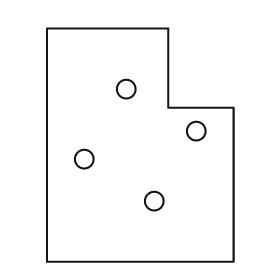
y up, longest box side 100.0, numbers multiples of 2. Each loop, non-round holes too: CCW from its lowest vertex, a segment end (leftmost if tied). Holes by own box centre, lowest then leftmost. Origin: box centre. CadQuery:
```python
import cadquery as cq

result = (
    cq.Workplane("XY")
    .moveTo(-40.0, -50.0)
    .lineTo(40.0, -50.0)
    .lineTo(40.0, 16.0)
    .lineTo(12.0, 16.0)
    .lineTo(12.0, 50.0)
    .lineTo(-40.0, 50.0)
    .close()
    .moveTo(6.0, -24.0)
    .circle(4.0)
    .moveTo(-24.0, -6.0)
    .circle(4.0)
    .moveTo(24.0, 6.0)
    .circle(4.0)
    .moveTo(-6.0, 24.0)
    .circle(4.0)
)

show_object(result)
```